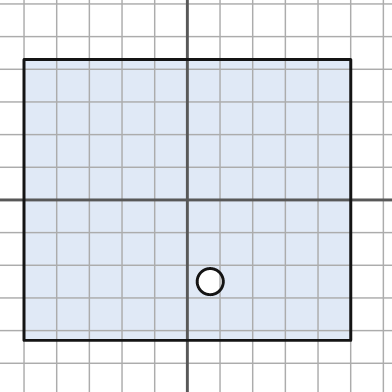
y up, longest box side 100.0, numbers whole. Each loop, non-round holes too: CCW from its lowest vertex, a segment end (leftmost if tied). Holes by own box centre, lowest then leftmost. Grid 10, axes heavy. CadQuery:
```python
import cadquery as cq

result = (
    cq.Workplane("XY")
    .moveTo(-50.0, -43.0)
    .lineTo(50.0, -43.0)
    .lineTo(50.0, 43.0)
    .lineTo(-50.0, 43.0)
    .close()
    .moveTo(7.0, -25.0)
    .circle(4.0)
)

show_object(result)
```